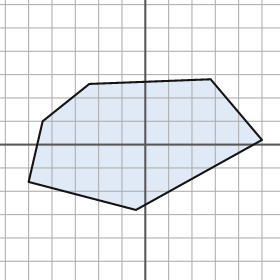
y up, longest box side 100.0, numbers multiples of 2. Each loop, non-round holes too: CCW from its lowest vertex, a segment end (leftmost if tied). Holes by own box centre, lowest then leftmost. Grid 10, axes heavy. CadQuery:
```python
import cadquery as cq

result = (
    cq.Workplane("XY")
    .moveTo(-4.0, -28.0)
    .lineTo(50.0, 2.0)
    .lineTo(28.0, 28.0)
    .lineTo(-24.0, 26.0)
    .lineTo(-44.0, 10.0)
    .lineTo(-50.0, -16.0)
    .close()
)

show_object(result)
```